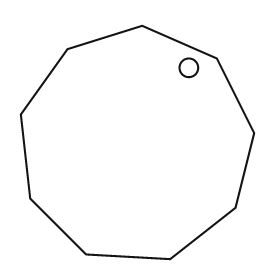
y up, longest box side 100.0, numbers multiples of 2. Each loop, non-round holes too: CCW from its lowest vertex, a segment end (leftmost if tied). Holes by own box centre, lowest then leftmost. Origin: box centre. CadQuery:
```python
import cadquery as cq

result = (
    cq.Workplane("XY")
    .moveTo(14.0, -50.0)
    .lineTo(42.0, -28.0)
    .lineTo(50.0, 4.0)
    .lineTo(34.0, 36.0)
    .lineTo(2.0, 50.0)
    .lineTo(-30.0, 40.0)
    .lineTo(-50.0, 12.0)
    .lineTo(-46.0, -24.0)
    .lineTo(-22.0, -48.0)
    .close()
    .moveTo(22.0, 32.0)
    .circle(4.0)
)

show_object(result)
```